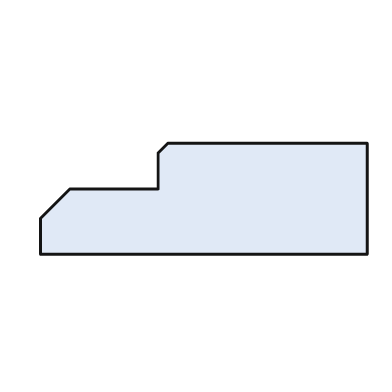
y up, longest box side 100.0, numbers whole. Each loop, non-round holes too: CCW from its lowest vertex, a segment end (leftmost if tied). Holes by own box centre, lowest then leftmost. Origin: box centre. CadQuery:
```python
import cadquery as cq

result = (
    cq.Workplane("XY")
    .moveTo(-50.0, -17.0)
    .lineTo(50.0, -17.0)
    .lineTo(50.0, 17.0)
    .lineTo(-11.0, 17.0)
    .lineTo(-14.0, 14.0)
    .lineTo(-14.0, 3.0)
    .lineTo(-41.0, 3.0)
    .lineTo(-50.0, -6.0)
    .close()
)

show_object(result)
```